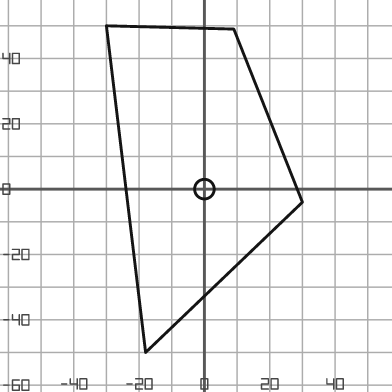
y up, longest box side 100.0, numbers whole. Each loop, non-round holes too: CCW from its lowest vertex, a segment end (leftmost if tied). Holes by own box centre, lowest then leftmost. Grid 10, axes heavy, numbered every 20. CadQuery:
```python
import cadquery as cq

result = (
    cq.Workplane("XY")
    .moveTo(-18.0, -50.0)
    .lineTo(30.0, -4.0)
    .lineTo(9.0, 49.0)
    .lineTo(-30.0, 50.0)
    .close()
    .moveTo(0.0, 0.0)
    .circle(3.0)
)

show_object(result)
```